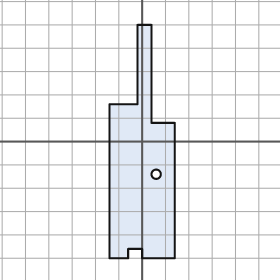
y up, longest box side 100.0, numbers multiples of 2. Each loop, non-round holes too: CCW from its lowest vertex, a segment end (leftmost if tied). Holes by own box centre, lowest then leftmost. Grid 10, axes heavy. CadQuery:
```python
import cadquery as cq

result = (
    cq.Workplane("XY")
    .moveTo(-14.0, -50.0)
    .lineTo(-6.0, -50.0)
    .lineTo(-6.0, -46.0)
    .lineTo(0.0, -46.0)
    .lineTo(0.0, -50.0)
    .lineTo(14.0, -50.0)
    .lineTo(14.0, 8.0)
    .lineTo(4.0, 8.0)
    .lineTo(4.0, 50.0)
    .lineTo(-2.0, 50.0)
    .lineTo(-2.0, 16.0)
    .lineTo(-14.0, 16.0)
    .close()
    .moveTo(6.0, -14.0)
    .circle(2.0)
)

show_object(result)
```